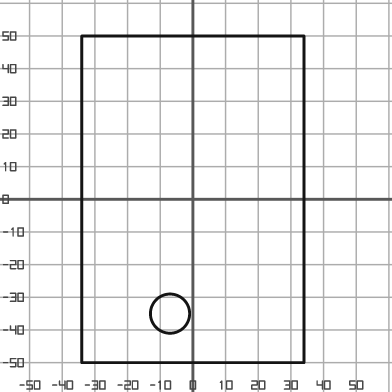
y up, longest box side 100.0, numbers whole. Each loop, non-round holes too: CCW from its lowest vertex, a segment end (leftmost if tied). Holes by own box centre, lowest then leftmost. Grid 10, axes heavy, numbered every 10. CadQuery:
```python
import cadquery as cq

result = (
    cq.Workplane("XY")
    .moveTo(-34.0, -50.0)
    .lineTo(34.0, -50.0)
    .lineTo(34.0, 50.0)
    .lineTo(-34.0, 50.0)
    .close()
    .moveTo(-7.0, -35.0)
    .circle(6.0)
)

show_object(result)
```